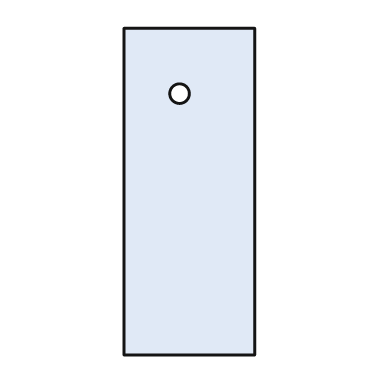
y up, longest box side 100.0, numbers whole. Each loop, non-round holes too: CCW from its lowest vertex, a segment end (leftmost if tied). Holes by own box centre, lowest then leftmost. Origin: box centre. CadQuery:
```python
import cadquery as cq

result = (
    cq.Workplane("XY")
    .moveTo(-20.0, -50.0)
    .lineTo(20.0, -50.0)
    .lineTo(20.0, 50.0)
    .lineTo(-20.0, 50.0)
    .close()
    .moveTo(-3.0, 30.0)
    .circle(3.0)
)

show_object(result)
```